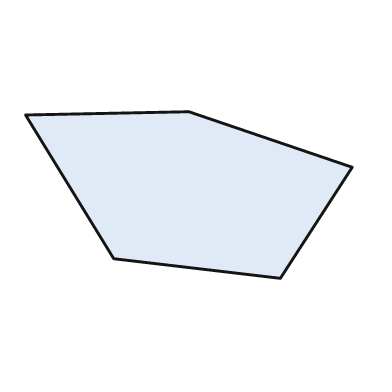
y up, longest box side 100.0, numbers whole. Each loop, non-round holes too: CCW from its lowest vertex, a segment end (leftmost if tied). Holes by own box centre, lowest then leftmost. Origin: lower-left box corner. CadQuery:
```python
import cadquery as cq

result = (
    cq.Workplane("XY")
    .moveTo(78.0, 0.0)
    .lineTo(100.0, 34.0)
    .lineTo(50.0, 51.0)
    .lineTo(0.0, 50.0)
    .lineTo(27.0, 6.0)
    .close()
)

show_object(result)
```